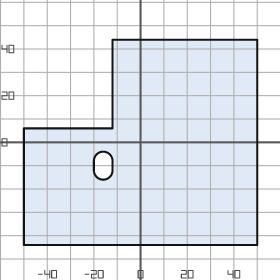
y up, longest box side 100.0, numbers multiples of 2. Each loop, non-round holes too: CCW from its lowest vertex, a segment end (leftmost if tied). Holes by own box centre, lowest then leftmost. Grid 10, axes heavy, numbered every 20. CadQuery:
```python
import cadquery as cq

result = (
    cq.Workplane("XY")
    .moveTo(-50.0, -44.0)
    .lineTo(50.0, -44.0)
    .lineTo(50.0, 44.0)
    .lineTo(-12.0, 44.0)
    .lineTo(-12.0, 6.0)
    .lineTo(-50.0, 6.0)
    .close()
    .moveTo(-20.0, -12.0)
    .threePointArc((-16.0, -16.0), (-12.0, -12.0))
    .lineTo(-12.0, -8.0)
    .threePointArc((-16.0, -4.0), (-20.0, -8.0))
    .close()
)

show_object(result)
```